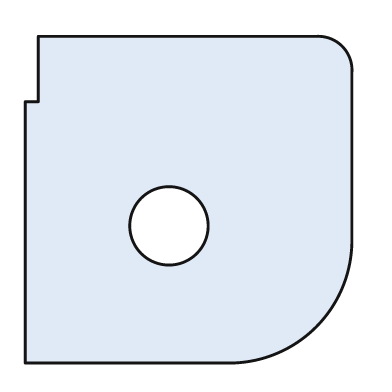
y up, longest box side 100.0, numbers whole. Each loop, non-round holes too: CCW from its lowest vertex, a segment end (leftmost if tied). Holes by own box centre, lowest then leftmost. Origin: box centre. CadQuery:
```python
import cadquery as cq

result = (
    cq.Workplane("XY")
    .moveTo(-50.0, -50.0)
    .lineTo(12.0, -50.0)
    .threePointArc((39.0, -39.0), (50.0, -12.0))
    .lineTo(50.0, 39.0)
    .threePointArc((47.0, 47.0), (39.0, 50.0))
    .lineTo(-46.0, 50.0)
    .lineTo(-46.0, 30.0)
    .lineTo(-50.0, 30.0)
    .close()
    .moveTo(-6.0, -8.0)
    .circle(12.0)
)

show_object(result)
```